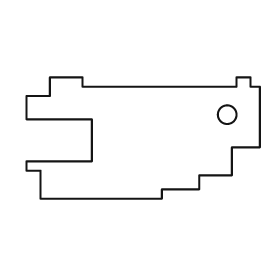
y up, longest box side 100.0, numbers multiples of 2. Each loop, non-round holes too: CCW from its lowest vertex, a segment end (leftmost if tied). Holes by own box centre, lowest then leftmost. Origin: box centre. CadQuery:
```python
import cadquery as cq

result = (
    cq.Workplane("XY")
    .moveTo(-44.0, -26.0)
    .lineTo(8.0, -26.0)
    .lineTo(8.0, -22.0)
    .lineTo(24.0, -22.0)
    .lineTo(24.0, -16.0)
    .lineTo(38.0, -16.0)
    .lineTo(38.0, -4.0)
    .lineTo(50.0, -4.0)
    .lineTo(50.0, 22.0)
    .lineTo(46.0, 22.0)
    .lineTo(46.0, 26.0)
    .lineTo(40.0, 26.0)
    .lineTo(40.0, 22.0)
    .lineTo(-26.0, 22.0)
    .lineTo(-26.0, 26.0)
    .lineTo(-40.0, 26.0)
    .lineTo(-40.0, 18.0)
    .lineTo(-50.0, 18.0)
    .lineTo(-50.0, 8.0)
    .lineTo(-22.0, 8.0)
    .lineTo(-22.0, -10.0)
    .lineTo(-50.0, -10.0)
    .lineTo(-50.0, -14.0)
    .lineTo(-44.0, -14.0)
    .close()
    .moveTo(36.0, 10.0)
    .circle(4.0)
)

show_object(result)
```